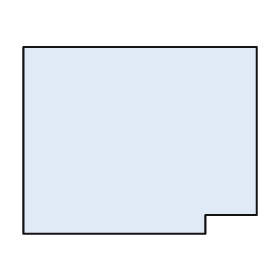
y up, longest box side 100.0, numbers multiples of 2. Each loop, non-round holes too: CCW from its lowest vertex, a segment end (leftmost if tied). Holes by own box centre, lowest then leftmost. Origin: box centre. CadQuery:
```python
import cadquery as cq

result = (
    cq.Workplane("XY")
    .moveTo(-50.0, -40.0)
    .lineTo(28.0, -40.0)
    .lineTo(28.0, -32.0)
    .lineTo(50.0, -32.0)
    .lineTo(50.0, 40.0)
    .lineTo(-50.0, 40.0)
    .close()
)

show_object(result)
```